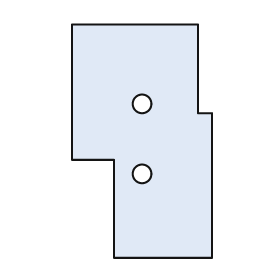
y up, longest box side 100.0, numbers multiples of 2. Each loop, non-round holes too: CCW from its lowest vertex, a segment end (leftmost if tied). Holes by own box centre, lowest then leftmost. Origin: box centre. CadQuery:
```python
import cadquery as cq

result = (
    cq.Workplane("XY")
    .moveTo(-12.0, -50.0)
    .lineTo(30.0, -50.0)
    .lineTo(30.0, 12.0)
    .lineTo(24.0, 12.0)
    .lineTo(24.0, 50.0)
    .lineTo(-30.0, 50.0)
    .lineTo(-30.0, -8.0)
    .lineTo(-12.0, -8.0)
    .close()
    .moveTo(0.0, -14.0)
    .circle(4.0)
    .moveTo(0.0, 16.0)
    .circle(4.0)
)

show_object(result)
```